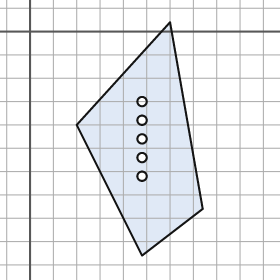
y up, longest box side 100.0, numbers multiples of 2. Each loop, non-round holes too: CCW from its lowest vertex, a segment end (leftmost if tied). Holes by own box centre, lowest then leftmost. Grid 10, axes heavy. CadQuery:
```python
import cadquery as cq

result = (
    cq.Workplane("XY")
    .moveTo(48.0, -96.0)
    .lineTo(74.0, -76.0)
    .lineTo(60.0, 4.0)
    .lineTo(20.0, -40.0)
    .close()
    .moveTo(48.0, -62.0)
    .circle(2.0)
    .moveTo(48.0, -54.0)
    .circle(2.0)
    .moveTo(48.0, -46.0)
    .circle(2.0)
    .moveTo(48.0, -38.0)
    .circle(2.0)
    .moveTo(48.0, -30.0)
    .circle(2.0)
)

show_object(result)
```